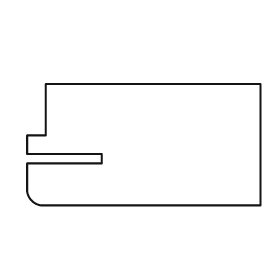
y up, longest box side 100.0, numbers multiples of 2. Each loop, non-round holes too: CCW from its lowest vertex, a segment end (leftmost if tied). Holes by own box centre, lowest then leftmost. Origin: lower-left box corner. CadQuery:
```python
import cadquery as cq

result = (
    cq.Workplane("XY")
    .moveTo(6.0, 0.0)
    .lineTo(100.0, 0.0)
    .lineTo(100.0, 52.0)
    .lineTo(8.0, 52.0)
    .lineTo(8.0, 30.0)
    .lineTo(0.0, 30.0)
    .lineTo(0.0, 22.0)
    .lineTo(32.0, 22.0)
    .lineTo(32.0, 18.0)
    .lineTo(0.0, 18.0)
    .lineTo(0.0, 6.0)
    .threePointArc((2.0, 2.0), (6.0, 0.0))
    .close()
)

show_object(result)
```